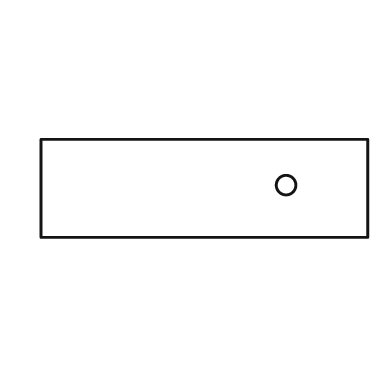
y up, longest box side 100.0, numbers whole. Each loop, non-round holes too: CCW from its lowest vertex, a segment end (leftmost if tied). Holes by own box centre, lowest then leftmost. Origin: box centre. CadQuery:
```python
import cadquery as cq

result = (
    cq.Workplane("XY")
    .moveTo(-50.0, -15.0)
    .lineTo(50.0, -15.0)
    .lineTo(50.0, 15.0)
    .lineTo(-50.0, 15.0)
    .close()
    .moveTo(25.0, 1.0)
    .circle(3.0)
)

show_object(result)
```